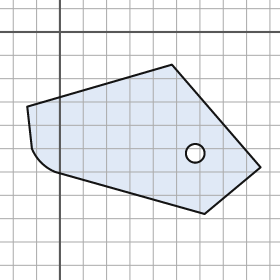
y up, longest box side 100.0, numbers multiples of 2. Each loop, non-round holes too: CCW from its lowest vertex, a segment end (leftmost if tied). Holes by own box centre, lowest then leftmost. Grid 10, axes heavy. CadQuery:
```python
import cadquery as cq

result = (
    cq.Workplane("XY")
    .moveTo(62.0, -78.0)
    .lineTo(86.0, -58.0)
    .lineTo(48.0, -14.0)
    .lineTo(-14.0, -32.0)
    .lineTo(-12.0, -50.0)
    .threePointArc((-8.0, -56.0), (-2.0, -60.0))
    .close()
    .moveTo(58.0, -52.0)
    .circle(4.0)
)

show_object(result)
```